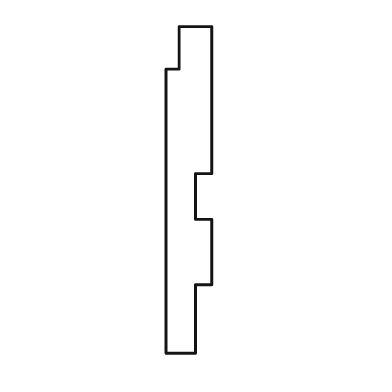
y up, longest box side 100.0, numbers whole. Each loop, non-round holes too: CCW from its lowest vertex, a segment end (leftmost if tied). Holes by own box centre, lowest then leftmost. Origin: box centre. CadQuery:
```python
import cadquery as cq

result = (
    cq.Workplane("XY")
    .moveTo(-7.0, -50.0)
    .lineTo(2.0, -50.0)
    .lineTo(2.0, -29.0)
    .lineTo(7.0, -29.0)
    .lineTo(7.0, -9.0)
    .lineTo(2.0, -9.0)
    .lineTo(2.0, 5.0)
    .lineTo(7.0, 5.0)
    .lineTo(7.0, 50.0)
    .lineTo(-3.0, 50.0)
    .lineTo(-3.0, 37.0)
    .lineTo(-7.0, 37.0)
    .close()
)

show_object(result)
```